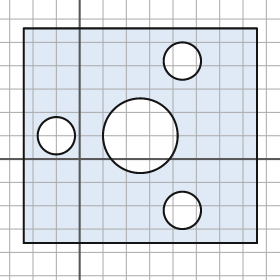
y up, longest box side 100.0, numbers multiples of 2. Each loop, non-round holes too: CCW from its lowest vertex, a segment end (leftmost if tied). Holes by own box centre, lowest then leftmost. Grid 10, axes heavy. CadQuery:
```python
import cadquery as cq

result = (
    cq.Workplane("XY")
    .moveTo(-24.0, -36.0)
    .lineTo(76.0, -36.0)
    .lineTo(76.0, 56.0)
    .lineTo(-24.0, 56.0)
    .close()
    .moveTo(44.0, -22.0)
    .circle(8.0)
    .moveTo(-10.0, 10.0)
    .circle(8.0)
    .moveTo(26.0, 10.0)
    .circle(16.0)
    .moveTo(44.0, 42.0)
    .circle(8.0)
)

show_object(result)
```